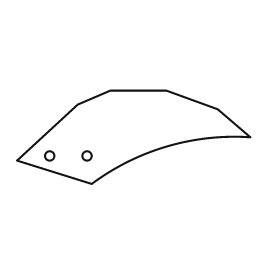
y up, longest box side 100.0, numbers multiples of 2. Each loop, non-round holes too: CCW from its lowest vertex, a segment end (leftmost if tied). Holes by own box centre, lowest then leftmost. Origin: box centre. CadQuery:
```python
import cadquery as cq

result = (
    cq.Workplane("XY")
    .moveTo(-18.0, -20.0)
    .threePointArc((14.0, -4.0), (50.0, 0.0))
    .lineTo(36.0, 12.0)
    .lineTo(14.0, 20.0)
    .lineTo(-10.0, 20.0)
    .lineTo(-24.0, 14.0)
    .lineTo(-50.0, -10.0)
    .close()
    .moveTo(-36.0, -8.0)
    .circle(2.0)
    .moveTo(-20.0, -8.0)
    .circle(2.0)
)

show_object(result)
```